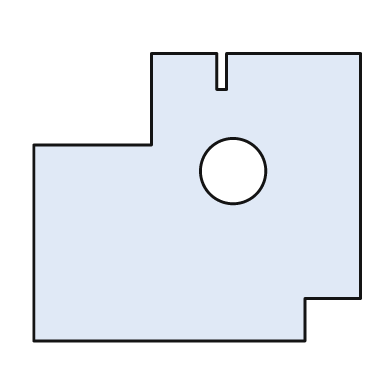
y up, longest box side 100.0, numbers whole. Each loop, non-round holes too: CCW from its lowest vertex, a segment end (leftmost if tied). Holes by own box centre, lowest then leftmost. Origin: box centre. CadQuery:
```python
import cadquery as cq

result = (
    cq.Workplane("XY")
    .moveTo(-50.0, -44.0)
    .lineTo(33.0, -44.0)
    .lineTo(33.0, -31.0)
    .lineTo(50.0, -31.0)
    .lineTo(50.0, 44.0)
    .lineTo(9.0, 44.0)
    .lineTo(9.0, 33.0)
    .lineTo(6.0, 33.0)
    .lineTo(6.0, 44.0)
    .lineTo(-14.0, 44.0)
    .lineTo(-14.0, 16.0)
    .lineTo(-50.0, 16.0)
    .close()
    .moveTo(11.0, 8.0)
    .circle(10.0)
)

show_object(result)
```